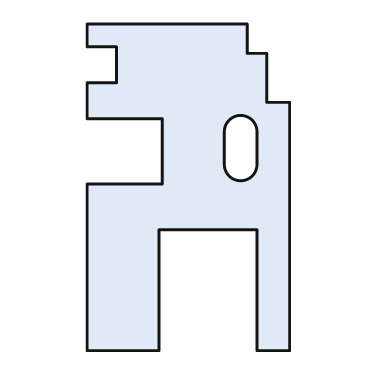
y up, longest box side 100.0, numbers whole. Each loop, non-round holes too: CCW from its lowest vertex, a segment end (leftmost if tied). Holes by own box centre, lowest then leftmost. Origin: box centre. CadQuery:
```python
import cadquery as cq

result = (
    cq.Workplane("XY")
    .moveTo(-31.0, -50.0)
    .lineTo(-9.0, -50.0)
    .lineTo(-9.0, -13.0)
    .lineTo(21.0, -13.0)
    .lineTo(21.0, -50.0)
    .lineTo(31.0, -50.0)
    .lineTo(31.0, 26.0)
    .lineTo(24.0, 26.0)
    .lineTo(24.0, 41.0)
    .lineTo(18.0, 41.0)
    .lineTo(18.0, 50.0)
    .lineTo(-31.0, 50.0)
    .lineTo(-31.0, 43.0)
    .lineTo(-22.0, 43.0)
    .lineTo(-22.0, 32.0)
    .lineTo(-31.0, 32.0)
    .lineTo(-31.0, 21.0)
    .lineTo(-8.0, 21.0)
    .lineTo(-8.0, 1.0)
    .lineTo(-31.0, 1.0)
    .close()
    .moveTo(11.0, 7.0)
    .threePointArc((16.0, 2.0), (21.0, 7.0))
    .lineTo(21.0, 17.0)
    .threePointArc((16.0, 22.0), (11.0, 17.0))
    .close()
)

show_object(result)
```